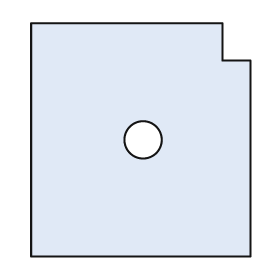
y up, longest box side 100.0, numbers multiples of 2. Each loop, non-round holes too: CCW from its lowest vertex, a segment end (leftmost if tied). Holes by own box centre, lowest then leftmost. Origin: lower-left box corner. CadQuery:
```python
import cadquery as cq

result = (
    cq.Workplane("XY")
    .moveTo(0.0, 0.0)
    .lineTo(94.0, 0.0)
    .lineTo(94.0, 84.0)
    .lineTo(82.0, 84.0)
    .lineTo(82.0, 100.0)
    .lineTo(0.0, 100.0)
    .close()
    .moveTo(48.0, 50.0)
    .circle(8.0)
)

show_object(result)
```